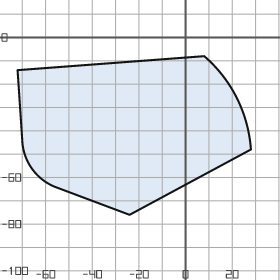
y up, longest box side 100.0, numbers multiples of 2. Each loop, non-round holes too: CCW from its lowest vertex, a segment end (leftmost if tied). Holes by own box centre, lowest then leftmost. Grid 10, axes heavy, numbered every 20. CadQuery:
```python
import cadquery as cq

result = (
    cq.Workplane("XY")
    .moveTo(-24.0, -76.0)
    .lineTo(28.0, -48.0)
    .threePointArc((22.0, -26.0), (8.0, -8.0))
    .lineTo(-72.0, -14.0)
    .lineTo(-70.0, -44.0)
    .threePointArc((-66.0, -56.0), (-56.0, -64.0))
    .close()
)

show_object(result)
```